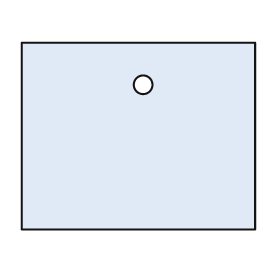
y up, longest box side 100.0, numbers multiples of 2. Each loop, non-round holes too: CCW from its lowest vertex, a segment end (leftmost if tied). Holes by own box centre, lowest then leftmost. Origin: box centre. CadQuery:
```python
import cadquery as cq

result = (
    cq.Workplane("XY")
    .moveTo(-50.0, -40.0)
    .lineTo(50.0, -40.0)
    .lineTo(50.0, 40.0)
    .lineTo(-50.0, 40.0)
    .close()
    .moveTo(2.0, 22.0)
    .circle(4.0)
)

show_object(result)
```